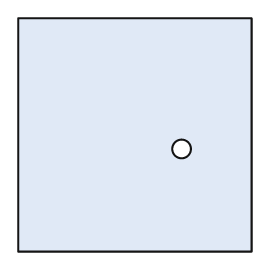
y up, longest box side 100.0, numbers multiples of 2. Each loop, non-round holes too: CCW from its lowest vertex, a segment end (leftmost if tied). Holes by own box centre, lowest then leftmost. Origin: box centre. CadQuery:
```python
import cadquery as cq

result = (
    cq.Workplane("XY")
    .moveTo(-50.0, -50.0)
    .lineTo(50.0, -50.0)
    .lineTo(50.0, 50.0)
    .lineTo(-50.0, 50.0)
    .close()
    .moveTo(20.0, -6.0)
    .circle(4.0)
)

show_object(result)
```